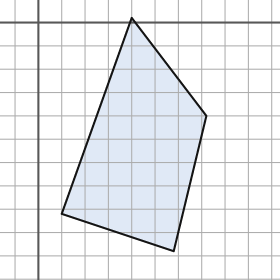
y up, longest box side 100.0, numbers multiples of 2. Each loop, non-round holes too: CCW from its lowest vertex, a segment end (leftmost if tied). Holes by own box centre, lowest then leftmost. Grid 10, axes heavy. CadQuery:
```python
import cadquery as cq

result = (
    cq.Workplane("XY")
    .moveTo(58.0, -98.0)
    .lineTo(72.0, -40.0)
    .lineTo(40.0, 2.0)
    .lineTo(10.0, -82.0)
    .close()
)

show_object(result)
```